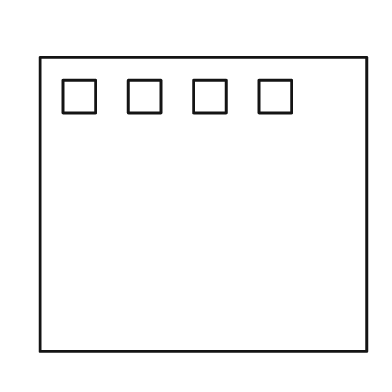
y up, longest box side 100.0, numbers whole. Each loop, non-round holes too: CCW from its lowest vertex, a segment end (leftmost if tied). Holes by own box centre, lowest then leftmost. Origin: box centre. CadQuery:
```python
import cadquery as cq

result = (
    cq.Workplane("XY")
    .moveTo(-50.0, -45.0)
    .lineTo(50.0, -45.0)
    .lineTo(50.0, 45.0)
    .lineTo(-50.0, 45.0)
    .close()
    .moveTo(-43.0, 28.0)
    .lineTo(-33.0, 28.0)
    .lineTo(-33.0, 38.0)
    .lineTo(-43.0, 38.0)
    .close()
    .moveTo(-23.0, 28.0)
    .lineTo(-13.0, 28.0)
    .lineTo(-13.0, 38.0)
    .lineTo(-23.0, 38.0)
    .close()
    .moveTo(-3.0, 28.0)
    .lineTo(7.0, 28.0)
    .lineTo(7.0, 38.0)
    .lineTo(-3.0, 38.0)
    .close()
    .moveTo(17.0, 28.0)
    .lineTo(27.0, 28.0)
    .lineTo(27.0, 38.0)
    .lineTo(17.0, 38.0)
    .close()
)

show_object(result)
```